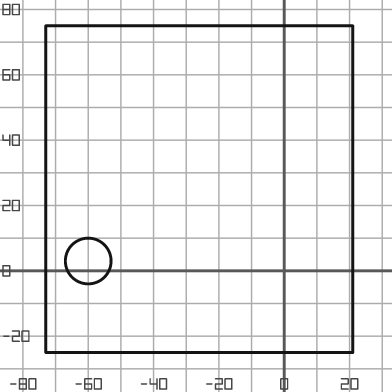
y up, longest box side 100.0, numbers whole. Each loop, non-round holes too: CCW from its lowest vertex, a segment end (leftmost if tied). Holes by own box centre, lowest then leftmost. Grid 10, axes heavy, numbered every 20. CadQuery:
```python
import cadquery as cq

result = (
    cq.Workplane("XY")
    .moveTo(-73.0, -25.0)
    .lineTo(21.0, -25.0)
    .lineTo(21.0, 75.0)
    .lineTo(-73.0, 75.0)
    .close()
    .moveTo(-60.0, 3.0)
    .circle(7.0)
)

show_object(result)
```